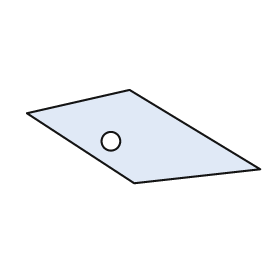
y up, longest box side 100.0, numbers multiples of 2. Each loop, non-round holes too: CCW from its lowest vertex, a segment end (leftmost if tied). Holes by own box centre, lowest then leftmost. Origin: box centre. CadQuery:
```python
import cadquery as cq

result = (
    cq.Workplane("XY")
    .moveTo(-4.0, -20.0)
    .lineTo(50.0, -14.0)
    .lineTo(-6.0, 20.0)
    .lineTo(-50.0, 10.0)
    .close()
    .moveTo(-14.0, -2.0)
    .circle(4.0)
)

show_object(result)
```